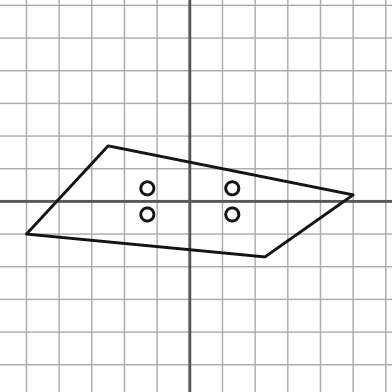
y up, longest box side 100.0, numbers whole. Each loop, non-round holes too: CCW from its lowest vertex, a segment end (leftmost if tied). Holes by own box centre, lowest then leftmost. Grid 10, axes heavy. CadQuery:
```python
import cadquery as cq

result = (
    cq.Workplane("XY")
    .moveTo(23.0, -17.0)
    .lineTo(50.0, 2.0)
    .lineTo(-25.0, 17.0)
    .lineTo(-50.0, -10.0)
    .close()
    .moveTo(-13.0, -4.0)
    .circle(2.0)
    .moveTo(13.0, -4.0)
    .circle(2.0)
    .moveTo(-13.0, 4.0)
    .circle(2.0)
    .moveTo(13.0, 4.0)
    .circle(2.0)
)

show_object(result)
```